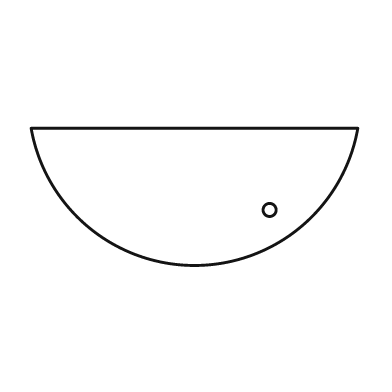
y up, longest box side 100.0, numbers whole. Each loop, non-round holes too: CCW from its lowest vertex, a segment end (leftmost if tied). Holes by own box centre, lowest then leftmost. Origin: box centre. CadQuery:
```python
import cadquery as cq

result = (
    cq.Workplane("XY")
    .moveTo(-50.0, 21.0)
    .threePointArc((0.0, -21.0), (50.0, 21.0))
    .close()
    .moveTo(23.0, -4.0)
    .circle(2.0)
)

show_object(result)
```